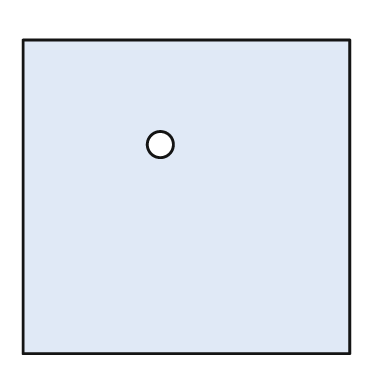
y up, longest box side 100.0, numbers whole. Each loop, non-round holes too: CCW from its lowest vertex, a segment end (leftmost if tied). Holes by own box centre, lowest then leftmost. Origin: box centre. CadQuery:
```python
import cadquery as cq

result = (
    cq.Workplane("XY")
    .moveTo(-50.0, -48.0)
    .lineTo(50.0, -48.0)
    .lineTo(50.0, 48.0)
    .lineTo(-50.0, 48.0)
    .close()
    .moveTo(-8.0, 16.0)
    .circle(4.0)
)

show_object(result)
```